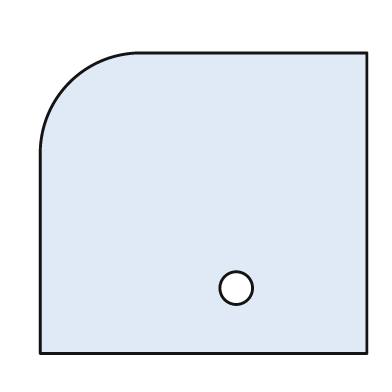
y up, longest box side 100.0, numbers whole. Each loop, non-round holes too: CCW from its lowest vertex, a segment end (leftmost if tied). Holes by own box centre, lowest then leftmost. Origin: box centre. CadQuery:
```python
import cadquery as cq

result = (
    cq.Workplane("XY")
    .moveTo(-50.0, -46.0)
    .lineTo(50.0, -46.0)
    .lineTo(50.0, 46.0)
    .lineTo(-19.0, 46.0)
    .threePointArc((-41.0, 37.0), (-50.0, 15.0))
    .close()
    .moveTo(10.0, -26.0)
    .circle(5.0)
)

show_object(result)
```